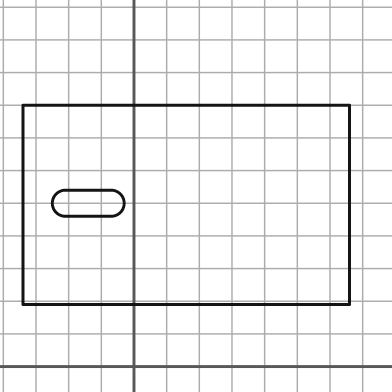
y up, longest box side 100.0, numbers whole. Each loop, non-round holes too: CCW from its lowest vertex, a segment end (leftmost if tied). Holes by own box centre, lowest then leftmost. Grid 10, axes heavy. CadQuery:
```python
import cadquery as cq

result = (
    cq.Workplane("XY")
    .moveTo(-34.0, 19.0)
    .lineTo(66.0, 19.0)
    .lineTo(66.0, 80.0)
    .lineTo(-34.0, 80.0)
    .close()
    .moveTo(-21.0, 46.0)
    .lineTo(-7.0, 46.0)
    .threePointArc((-3.0, 50.0), (-7.0, 54.0))
    .lineTo(-21.0, 54.0)
    .threePointArc((-25.0, 50.0), (-21.0, 46.0))
    .close()
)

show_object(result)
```